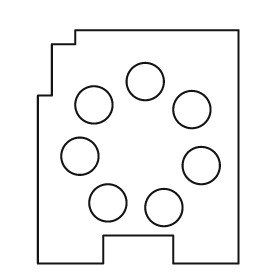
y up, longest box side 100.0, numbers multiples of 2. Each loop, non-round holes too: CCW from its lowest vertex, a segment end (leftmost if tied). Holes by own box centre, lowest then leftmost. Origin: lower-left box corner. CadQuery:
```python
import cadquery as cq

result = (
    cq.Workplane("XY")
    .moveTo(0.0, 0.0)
    .lineTo(28.0, 0.0)
    .lineTo(28.0, 12.0)
    .lineTo(58.0, 12.0)
    .lineTo(58.0, 0.0)
    .lineTo(86.0, 0.0)
    .lineTo(86.0, 100.0)
    .lineTo(16.0, 100.0)
    .lineTo(16.0, 94.0)
    .lineTo(6.0, 94.0)
    .lineTo(6.0, 72.0)
    .lineTo(0.0, 72.0)
    .close()
    .moveTo(54.0, 24.0)
    .circle(8.0)
    .moveTo(30.0, 26.0)
    .circle(8.0)
    .moveTo(70.0, 42.0)
    .circle(8.0)
    .moveTo(18.0, 46.0)
    .circle(8.0)
    .moveTo(66.0, 66.0)
    .circle(8.0)
    .moveTo(24.0, 68.0)
    .circle(8.0)
    .moveTo(46.0, 78.0)
    .circle(8.0)
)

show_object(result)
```